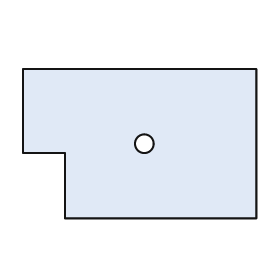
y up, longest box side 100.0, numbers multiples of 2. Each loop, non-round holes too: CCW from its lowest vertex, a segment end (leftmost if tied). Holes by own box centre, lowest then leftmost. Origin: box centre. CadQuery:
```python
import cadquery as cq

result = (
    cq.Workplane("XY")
    .moveTo(-32.0, -32.0)
    .lineTo(50.0, -32.0)
    .lineTo(50.0, 32.0)
    .lineTo(-50.0, 32.0)
    .lineTo(-50.0, -4.0)
    .lineTo(-32.0, -4.0)
    .close()
    .moveTo(2.0, 0.0)
    .circle(4.0)
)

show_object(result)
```